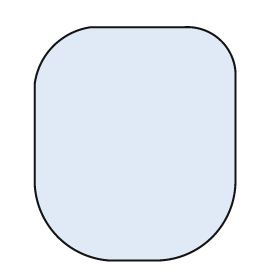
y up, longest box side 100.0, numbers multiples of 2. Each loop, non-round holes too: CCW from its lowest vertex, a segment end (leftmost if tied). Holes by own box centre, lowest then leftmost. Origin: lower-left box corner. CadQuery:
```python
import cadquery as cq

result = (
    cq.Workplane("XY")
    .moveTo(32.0, 0.0)
    .lineTo(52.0, 0.0)
    .threePointArc((76.0, 10.0), (86.0, 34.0))
    .lineTo(86.0, 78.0)
    .threePointArc((80.0, 94.0), (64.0, 100.0))
    .lineTo(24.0, 100.0)
    .threePointArc((8.0, 92.0), (0.0, 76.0))
    .lineTo(0.0, 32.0)
    .threePointArc((10.0, 10.0), (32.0, 0.0))
    .close()
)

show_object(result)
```